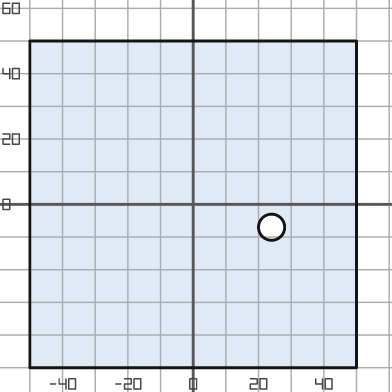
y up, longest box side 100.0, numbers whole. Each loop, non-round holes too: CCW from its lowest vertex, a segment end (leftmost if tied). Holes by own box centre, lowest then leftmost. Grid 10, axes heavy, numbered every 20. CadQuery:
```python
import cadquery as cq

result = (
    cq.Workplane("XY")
    .moveTo(-50.0, -50.0)
    .lineTo(50.0, -50.0)
    .lineTo(50.0, 50.0)
    .lineTo(-50.0, 50.0)
    .close()
    .moveTo(24.0, -7.0)
    .circle(4.0)
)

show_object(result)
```